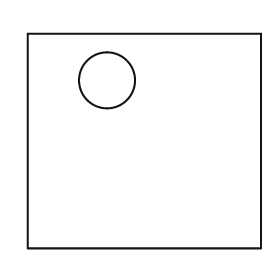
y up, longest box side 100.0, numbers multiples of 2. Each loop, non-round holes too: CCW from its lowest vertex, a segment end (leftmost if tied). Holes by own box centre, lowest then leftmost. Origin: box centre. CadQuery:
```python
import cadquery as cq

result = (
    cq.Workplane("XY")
    .moveTo(-50.0, -46.0)
    .lineTo(50.0, -46.0)
    .lineTo(50.0, 46.0)
    .lineTo(-50.0, 46.0)
    .close()
    .moveTo(-16.0, 26.0)
    .circle(12.0)
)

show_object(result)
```